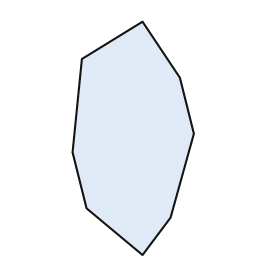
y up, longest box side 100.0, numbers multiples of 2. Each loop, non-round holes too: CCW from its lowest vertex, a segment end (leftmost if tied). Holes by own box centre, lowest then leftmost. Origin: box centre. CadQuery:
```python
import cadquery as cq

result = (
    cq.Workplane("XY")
    .moveTo(4.0, -50.0)
    .lineTo(16.0, -34.0)
    .lineTo(26.0, 2.0)
    .lineTo(20.0, 26.0)
    .lineTo(4.0, 50.0)
    .lineTo(-22.0, 34.0)
    .lineTo(-26.0, -6.0)
    .lineTo(-20.0, -30.0)
    .close()
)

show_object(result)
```